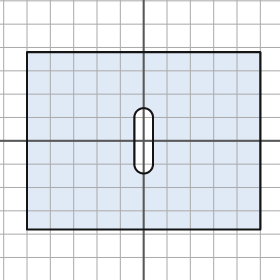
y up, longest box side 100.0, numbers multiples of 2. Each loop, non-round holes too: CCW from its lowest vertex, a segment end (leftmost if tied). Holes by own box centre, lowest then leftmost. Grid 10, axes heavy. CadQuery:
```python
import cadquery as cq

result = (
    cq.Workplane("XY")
    .moveTo(-50.0, -38.0)
    .lineTo(50.0, -38.0)
    .lineTo(50.0, 38.0)
    .lineTo(-50.0, 38.0)
    .close()
    .moveTo(-4.0, -10.0)
    .threePointArc((0.0, -14.0), (4.0, -10.0))
    .lineTo(4.0, 10.0)
    .threePointArc((0.0, 14.0), (-4.0, 10.0))
    .close()
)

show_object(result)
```